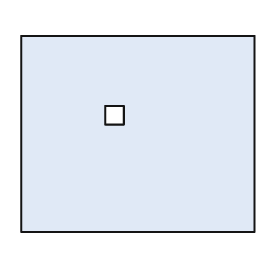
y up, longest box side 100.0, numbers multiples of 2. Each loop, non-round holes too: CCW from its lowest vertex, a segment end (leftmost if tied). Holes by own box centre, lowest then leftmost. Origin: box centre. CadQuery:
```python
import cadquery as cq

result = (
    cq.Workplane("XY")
    .moveTo(-50.0, -42.0)
    .lineTo(50.0, -42.0)
    .lineTo(50.0, 42.0)
    .lineTo(-50.0, 42.0)
    .close()
    .moveTo(-14.0, 4.0)
    .lineTo(-6.0, 4.0)
    .lineTo(-6.0, 12.0)
    .lineTo(-14.0, 12.0)
    .close()
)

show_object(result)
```